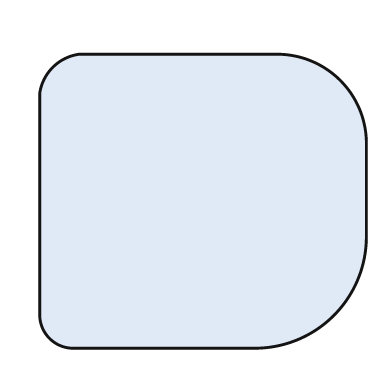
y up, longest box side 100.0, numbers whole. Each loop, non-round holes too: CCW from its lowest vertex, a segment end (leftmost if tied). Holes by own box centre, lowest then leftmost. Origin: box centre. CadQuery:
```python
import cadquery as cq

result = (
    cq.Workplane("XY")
    .moveTo(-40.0, -45.0)
    .lineTo(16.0, -45.0)
    .threePointArc((40.0, -35.0), (50.0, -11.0))
    .lineTo(50.0, 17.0)
    .threePointArc((42.0, 37.0), (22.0, 45.0))
    .lineTo(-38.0, 45.0)
    .threePointArc((-46.0, 41.0), (-50.0, 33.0))
    .lineTo(-50.0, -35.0)
    .threePointArc((-47.0, -42.0), (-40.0, -45.0))
    .close()
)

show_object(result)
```